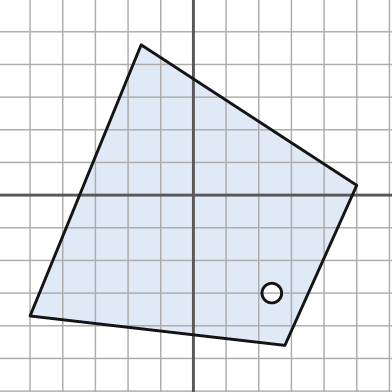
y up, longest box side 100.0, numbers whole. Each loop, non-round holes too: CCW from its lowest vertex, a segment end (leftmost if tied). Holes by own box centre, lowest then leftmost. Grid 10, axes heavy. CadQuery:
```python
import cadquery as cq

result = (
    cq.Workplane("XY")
    .moveTo(28.0, -46.0)
    .lineTo(50.0, 3.0)
    .lineTo(-16.0, 46.0)
    .lineTo(-50.0, -37.0)
    .close()
    .moveTo(24.0, -30.0)
    .circle(3.0)
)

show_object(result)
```